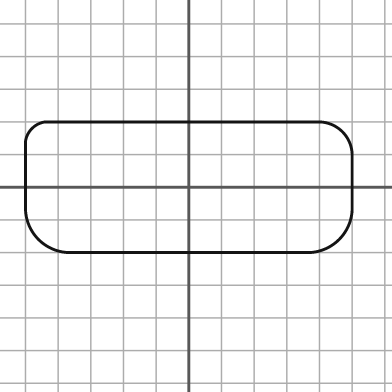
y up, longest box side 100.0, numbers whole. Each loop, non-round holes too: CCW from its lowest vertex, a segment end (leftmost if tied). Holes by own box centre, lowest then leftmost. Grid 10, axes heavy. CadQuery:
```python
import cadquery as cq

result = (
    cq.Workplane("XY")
    .moveTo(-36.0, -20.0)
    .lineTo(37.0, -20.0)
    .threePointArc((46.0, -16.0), (50.0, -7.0))
    .lineTo(50.0, 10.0)
    .threePointArc((47.0, 17.0), (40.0, 20.0))
    .lineTo(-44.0, 20.0)
    .threePointArc((-48.0, 18.0), (-50.0, 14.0))
    .lineTo(-50.0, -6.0)
    .threePointArc((-46.0, -16.0), (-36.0, -20.0))
    .close()
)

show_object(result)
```